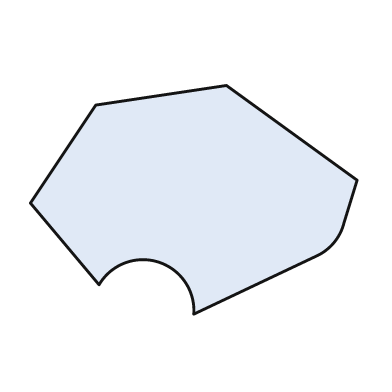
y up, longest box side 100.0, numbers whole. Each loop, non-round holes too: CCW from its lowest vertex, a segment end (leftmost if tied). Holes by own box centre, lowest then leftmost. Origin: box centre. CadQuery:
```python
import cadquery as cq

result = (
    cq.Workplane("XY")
    .moveTo(0.0, -35.0)
    .lineTo(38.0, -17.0)
    .threePointArc((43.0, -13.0), (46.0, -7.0))
    .lineTo(50.0, 6.0)
    .lineTo(10.0, 35.0)
    .lineTo(-30.0, 29.0)
    .lineTo(-50.0, -1.0)
    .lineTo(-29.0, -26.0)
    .threePointArc((-11.0, -19.0), (0.0, -35.0))
    .close()
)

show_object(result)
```